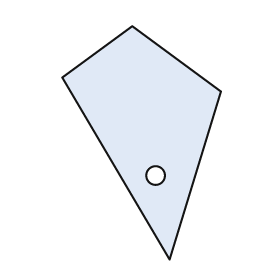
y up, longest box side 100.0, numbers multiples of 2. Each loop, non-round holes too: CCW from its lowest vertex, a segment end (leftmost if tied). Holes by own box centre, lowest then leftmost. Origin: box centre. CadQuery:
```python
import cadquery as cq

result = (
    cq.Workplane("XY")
    .moveTo(12.0, -50.0)
    .lineTo(34.0, 22.0)
    .lineTo(-4.0, 50.0)
    .lineTo(-34.0, 28.0)
    .close()
    .moveTo(6.0, -14.0)
    .circle(4.0)
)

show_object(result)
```